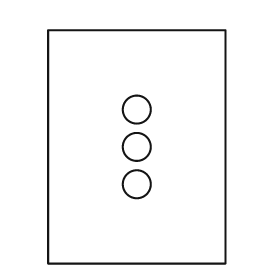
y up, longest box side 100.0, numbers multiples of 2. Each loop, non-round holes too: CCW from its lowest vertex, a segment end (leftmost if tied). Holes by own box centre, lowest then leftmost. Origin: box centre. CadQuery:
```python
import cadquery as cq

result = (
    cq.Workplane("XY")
    .moveTo(-38.0, -50.0)
    .lineTo(38.0, -50.0)
    .lineTo(38.0, 50.0)
    .lineTo(-38.0, 50.0)
    .close()
    .moveTo(0.0, -16.0)
    .circle(6.0)
    .moveTo(0.0, 0.0)
    .circle(6.0)
    .moveTo(0.0, 16.0)
    .circle(6.0)
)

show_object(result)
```